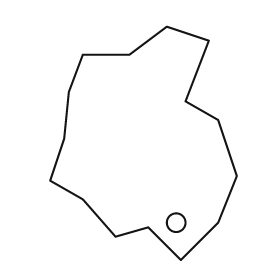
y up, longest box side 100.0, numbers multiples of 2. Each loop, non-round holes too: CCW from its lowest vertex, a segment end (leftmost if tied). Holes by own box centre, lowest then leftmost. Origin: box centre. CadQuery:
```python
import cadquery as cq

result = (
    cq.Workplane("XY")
    .moveTo(16.0, -50.0)
    .lineTo(32.0, -34.0)
    .lineTo(40.0, -14.0)
    .lineTo(32.0, 10.0)
    .lineTo(18.0, 18.0)
    .lineTo(28.0, 44.0)
    .lineTo(10.0, 50.0)
    .lineTo(-6.0, 38.0)
    .lineTo(-26.0, 38.0)
    .lineTo(-32.0, 22.0)
    .lineTo(-34.0, 2.0)
    .lineTo(-40.0, -16.0)
    .lineTo(-26.0, -24.0)
    .lineTo(-12.0, -40.0)
    .lineTo(2.0, -36.0)
    .close()
    .moveTo(14.0, -34.0)
    .circle(4.0)
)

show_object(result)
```